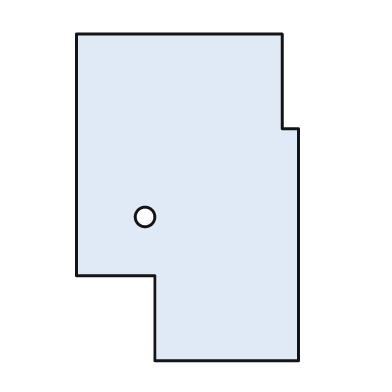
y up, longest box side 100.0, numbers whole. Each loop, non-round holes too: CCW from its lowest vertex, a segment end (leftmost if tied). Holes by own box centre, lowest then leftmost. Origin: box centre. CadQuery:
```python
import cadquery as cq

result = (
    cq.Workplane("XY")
    .moveTo(-10.0, -50.0)
    .lineTo(34.0, -50.0)
    .lineTo(34.0, 21.0)
    .lineTo(29.0, 21.0)
    .lineTo(29.0, 50.0)
    .lineTo(-34.0, 50.0)
    .lineTo(-34.0, -24.0)
    .lineTo(-10.0, -24.0)
    .close()
    .moveTo(-13.0, -6.0)
    .circle(3.0)
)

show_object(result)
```